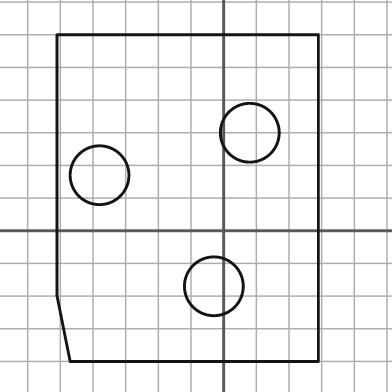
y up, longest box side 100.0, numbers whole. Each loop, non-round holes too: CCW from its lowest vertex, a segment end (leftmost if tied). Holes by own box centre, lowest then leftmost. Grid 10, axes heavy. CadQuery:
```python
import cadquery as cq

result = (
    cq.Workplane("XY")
    .moveTo(-47.0, -40.0)
    .lineTo(29.0, -40.0)
    .lineTo(29.0, 60.0)
    .lineTo(-51.0, 60.0)
    .lineTo(-51.0, -20.0)
    .close()
    .moveTo(-3.0, -17.0)
    .circle(9.0)
    .moveTo(-38.0, 17.0)
    .circle(9.0)
    .moveTo(8.0, 30.0)
    .circle(9.0)
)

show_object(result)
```